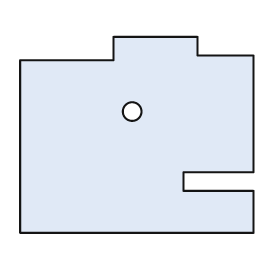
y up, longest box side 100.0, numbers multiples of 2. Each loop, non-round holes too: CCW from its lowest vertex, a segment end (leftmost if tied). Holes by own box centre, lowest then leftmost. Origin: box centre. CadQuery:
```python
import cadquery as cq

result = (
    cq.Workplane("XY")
    .moveTo(-50.0, -42.0)
    .lineTo(50.0, -42.0)
    .lineTo(50.0, -24.0)
    .lineTo(20.0, -24.0)
    .lineTo(20.0, -16.0)
    .lineTo(50.0, -16.0)
    .lineTo(50.0, 34.0)
    .lineTo(26.0, 34.0)
    .lineTo(26.0, 42.0)
    .lineTo(-10.0, 42.0)
    .lineTo(-10.0, 32.0)
    .lineTo(-50.0, 32.0)
    .close()
    .moveTo(-2.0, 10.0)
    .circle(4.0)
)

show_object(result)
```